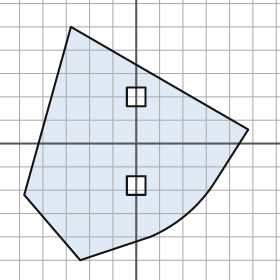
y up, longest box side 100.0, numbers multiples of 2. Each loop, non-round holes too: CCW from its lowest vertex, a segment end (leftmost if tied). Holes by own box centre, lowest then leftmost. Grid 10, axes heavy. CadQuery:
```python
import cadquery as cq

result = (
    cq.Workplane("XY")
    .moveTo(-24.0, -50.0)
    .lineTo(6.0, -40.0)
    .threePointArc((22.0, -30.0), (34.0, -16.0))
    .lineTo(48.0, 6.0)
    .lineTo(-28.0, 50.0)
    .lineTo(-48.0, -22.0)
    .close()
    .moveTo(-4.0, -22.0)
    .lineTo(4.0, -22.0)
    .lineTo(4.0, -14.0)
    .lineTo(-4.0, -14.0)
    .close()
    .moveTo(-4.0, 16.0)
    .lineTo(4.0, 16.0)
    .lineTo(4.0, 24.0)
    .lineTo(-4.0, 24.0)
    .close()
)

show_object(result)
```